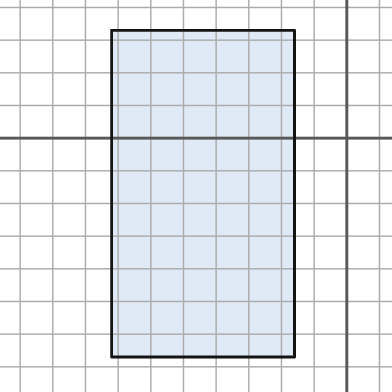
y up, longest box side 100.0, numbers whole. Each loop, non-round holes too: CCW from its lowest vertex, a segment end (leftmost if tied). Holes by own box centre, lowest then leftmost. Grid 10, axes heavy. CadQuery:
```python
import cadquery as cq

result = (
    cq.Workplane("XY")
    .moveTo(-72.0, -67.0)
    .lineTo(-16.0, -67.0)
    .lineTo(-16.0, 33.0)
    .lineTo(-72.0, 33.0)
    .close()
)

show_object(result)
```